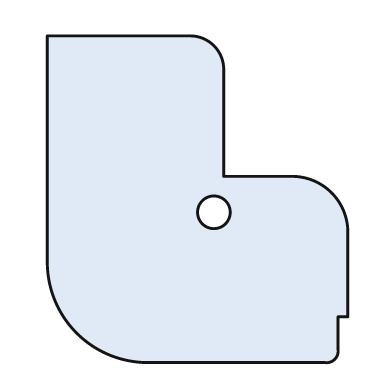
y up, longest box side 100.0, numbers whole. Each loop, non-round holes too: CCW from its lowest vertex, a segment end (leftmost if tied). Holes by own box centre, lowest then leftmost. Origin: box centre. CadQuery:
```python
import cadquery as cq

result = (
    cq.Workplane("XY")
    .moveTo(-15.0, -50.0)
    .lineTo(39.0, -50.0)
    .threePointArc((42.0, -49.0), (43.0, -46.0))
    .lineTo(43.0, -36.0)
    .lineTo(46.0, -36.0)
    .lineTo(46.0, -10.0)
    .threePointArc((41.0, 2.0), (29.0, 7.0))
    .lineTo(8.0, 7.0)
    .lineTo(8.0, 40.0)
    .threePointArc((5.0, 47.0), (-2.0, 50.0))
    .lineTo(-46.0, 50.0)
    .lineTo(-46.0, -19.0)
    .threePointArc((-37.0, -41.0), (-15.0, -50.0))
    .close()
    .moveTo(5.0, -4.0)
    .circle(5.0)
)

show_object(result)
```